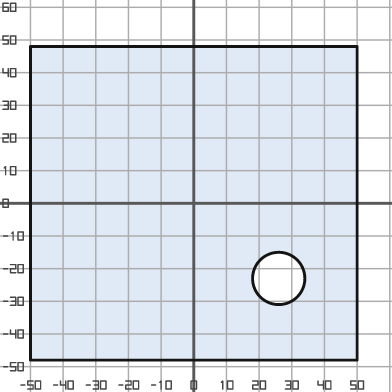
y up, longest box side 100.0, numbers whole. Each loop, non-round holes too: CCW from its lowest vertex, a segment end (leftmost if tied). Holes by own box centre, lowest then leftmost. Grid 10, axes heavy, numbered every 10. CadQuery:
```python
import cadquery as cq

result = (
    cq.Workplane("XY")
    .moveTo(-50.0, -48.0)
    .lineTo(50.0, -48.0)
    .lineTo(50.0, 48.0)
    .lineTo(-50.0, 48.0)
    .close()
    .moveTo(26.0, -23.0)
    .circle(8.0)
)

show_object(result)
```